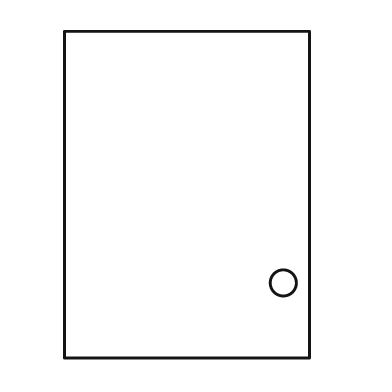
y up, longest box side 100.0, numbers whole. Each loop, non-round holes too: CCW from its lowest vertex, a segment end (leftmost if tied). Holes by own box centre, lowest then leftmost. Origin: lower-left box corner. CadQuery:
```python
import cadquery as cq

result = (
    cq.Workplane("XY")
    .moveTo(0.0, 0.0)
    .lineTo(75.0, 0.0)
    .lineTo(75.0, 100.0)
    .lineTo(0.0, 100.0)
    .close()
    .moveTo(67.0, 23.0)
    .circle(4.0)
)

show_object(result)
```